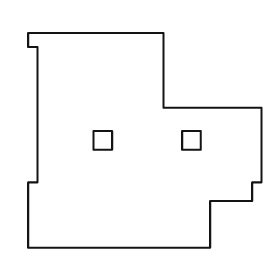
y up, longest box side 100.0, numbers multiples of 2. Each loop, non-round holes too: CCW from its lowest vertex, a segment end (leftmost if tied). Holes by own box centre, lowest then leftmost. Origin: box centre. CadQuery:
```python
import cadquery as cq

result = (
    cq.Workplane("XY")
    .moveTo(-50.0, -46.0)
    .lineTo(28.0, -46.0)
    .lineTo(28.0, -26.0)
    .lineTo(46.0, -26.0)
    .lineTo(46.0, -18.0)
    .lineTo(50.0, -18.0)
    .lineTo(50.0, 14.0)
    .lineTo(8.0, 14.0)
    .lineTo(8.0, 46.0)
    .lineTo(-50.0, 46.0)
    .lineTo(-50.0, 40.0)
    .lineTo(-46.0, 40.0)
    .lineTo(-46.0, -18.0)
    .lineTo(-50.0, -18.0)
    .close()
    .moveTo(-22.0, -4.0)
    .lineTo(-14.0, -4.0)
    .lineTo(-14.0, 4.0)
    .lineTo(-22.0, 4.0)
    .close()
    .moveTo(16.0, -4.0)
    .lineTo(24.0, -4.0)
    .lineTo(24.0, 4.0)
    .lineTo(16.0, 4.0)
    .close()
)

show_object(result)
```